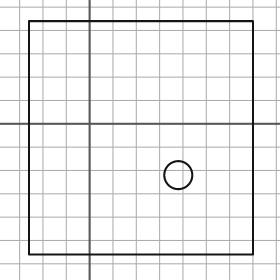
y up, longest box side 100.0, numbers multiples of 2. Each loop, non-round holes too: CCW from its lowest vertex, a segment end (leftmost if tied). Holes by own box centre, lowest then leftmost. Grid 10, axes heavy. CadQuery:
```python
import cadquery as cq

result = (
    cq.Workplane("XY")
    .moveTo(-26.0, -56.0)
    .lineTo(70.0, -56.0)
    .lineTo(70.0, 44.0)
    .lineTo(-26.0, 44.0)
    .close()
    .moveTo(38.0, -22.0)
    .circle(6.0)
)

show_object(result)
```